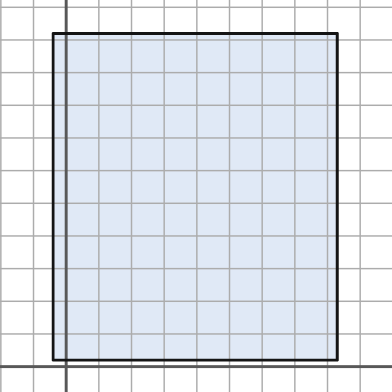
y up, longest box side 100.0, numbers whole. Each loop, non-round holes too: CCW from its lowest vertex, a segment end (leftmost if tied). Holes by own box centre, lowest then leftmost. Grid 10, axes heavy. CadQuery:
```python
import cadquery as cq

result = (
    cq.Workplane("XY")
    .moveTo(-4.0, 2.0)
    .lineTo(83.0, 2.0)
    .lineTo(83.0, 102.0)
    .lineTo(-4.0, 102.0)
    .close()
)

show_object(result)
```